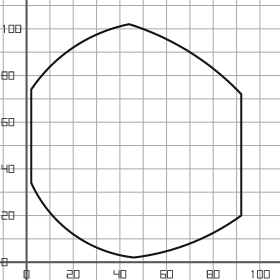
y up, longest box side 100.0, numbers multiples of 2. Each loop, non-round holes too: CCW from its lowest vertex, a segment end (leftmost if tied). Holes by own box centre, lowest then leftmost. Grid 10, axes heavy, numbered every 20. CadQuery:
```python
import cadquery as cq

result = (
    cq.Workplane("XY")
    .moveTo(46.0, 2.0)
    .threePointArc((70.0, 8.0), (92.0, 20.0))
    .lineTo(92.0, 72.0)
    .threePointArc((70.0, 90.0), (44.0, 102.0))
    .threePointArc((20.0, 92.0), (2.0, 74.0))
    .lineTo(2.0, 34.0)
    .threePointArc((20.0, 12.0), (46.0, 2.0))
    .close()
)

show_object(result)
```